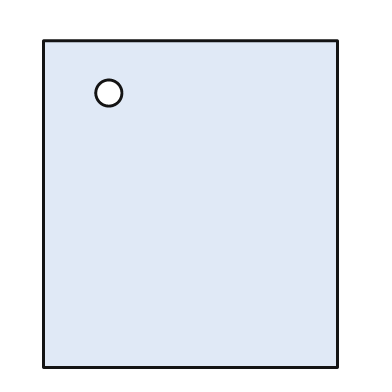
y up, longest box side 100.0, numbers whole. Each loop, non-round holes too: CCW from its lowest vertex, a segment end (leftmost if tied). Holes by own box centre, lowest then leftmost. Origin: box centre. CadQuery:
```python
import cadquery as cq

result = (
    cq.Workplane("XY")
    .moveTo(-45.0, -50.0)
    .lineTo(45.0, -50.0)
    .lineTo(45.0, 50.0)
    .lineTo(-45.0, 50.0)
    .close()
    .moveTo(-25.0, 34.0)
    .circle(4.0)
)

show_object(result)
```